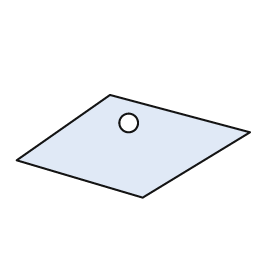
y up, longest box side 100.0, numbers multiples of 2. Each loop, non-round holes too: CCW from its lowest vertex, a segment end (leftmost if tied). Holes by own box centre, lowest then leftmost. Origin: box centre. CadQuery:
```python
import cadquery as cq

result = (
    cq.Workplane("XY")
    .moveTo(4.0, -22.0)
    .lineTo(50.0, 6.0)
    .lineTo(-10.0, 22.0)
    .lineTo(-50.0, -6.0)
    .close()
    .moveTo(-2.0, 10.0)
    .circle(4.0)
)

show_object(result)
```